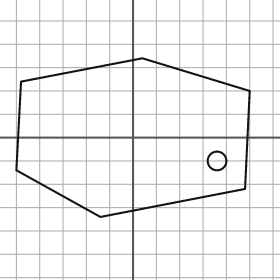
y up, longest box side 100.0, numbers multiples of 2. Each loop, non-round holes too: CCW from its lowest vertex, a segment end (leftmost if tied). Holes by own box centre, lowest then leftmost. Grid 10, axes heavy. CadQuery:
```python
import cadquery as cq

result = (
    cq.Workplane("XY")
    .moveTo(-14.0, -34.0)
    .lineTo(48.0, -22.0)
    .lineTo(50.0, 20.0)
    .lineTo(4.0, 34.0)
    .lineTo(-48.0, 24.0)
    .lineTo(-50.0, -14.0)
    .close()
    .moveTo(36.0, -10.0)
    .circle(4.0)
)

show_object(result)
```